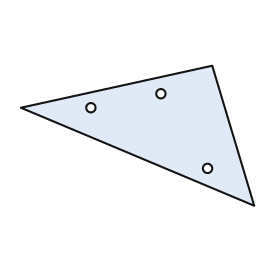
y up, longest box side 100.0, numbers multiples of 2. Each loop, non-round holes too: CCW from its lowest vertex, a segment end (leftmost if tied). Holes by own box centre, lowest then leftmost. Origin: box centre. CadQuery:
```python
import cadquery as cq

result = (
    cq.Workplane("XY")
    .moveTo(50.0, -30.0)
    .lineTo(32.0, 30.0)
    .lineTo(-50.0, 12.0)
    .close()
    .moveTo(30.0, -14.0)
    .circle(2.0)
    .moveTo(-20.0, 12.0)
    .circle(2.0)
    .moveTo(10.0, 18.0)
    .circle(2.0)
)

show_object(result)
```